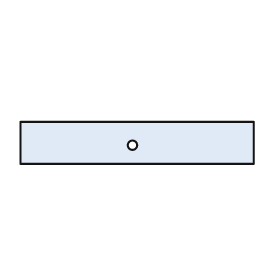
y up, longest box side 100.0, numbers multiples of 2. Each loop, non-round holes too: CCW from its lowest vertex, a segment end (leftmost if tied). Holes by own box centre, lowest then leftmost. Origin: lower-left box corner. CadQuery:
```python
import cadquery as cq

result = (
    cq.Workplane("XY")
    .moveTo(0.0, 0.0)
    .lineTo(100.0, 0.0)
    .lineTo(100.0, 18.0)
    .lineTo(0.0, 18.0)
    .close()
    .moveTo(48.0, 8.0)
    .circle(2.0)
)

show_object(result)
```